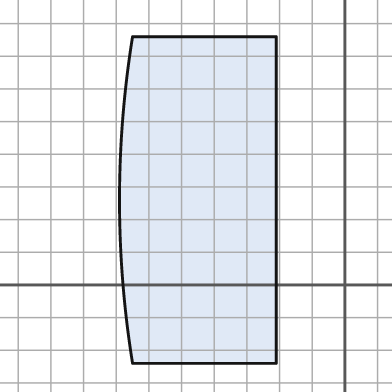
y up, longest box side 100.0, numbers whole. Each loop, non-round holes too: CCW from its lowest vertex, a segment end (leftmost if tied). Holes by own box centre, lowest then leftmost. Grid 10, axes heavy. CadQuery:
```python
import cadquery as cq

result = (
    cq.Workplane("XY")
    .moveTo(-65.0, -24.0)
    .lineTo(-21.0, -24.0)
    .lineTo(-21.0, 76.0)
    .lineTo(-65.0, 76.0)
    .threePointArc((-69.0, 26.0), (-65.0, -24.0))
    .close()
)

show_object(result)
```